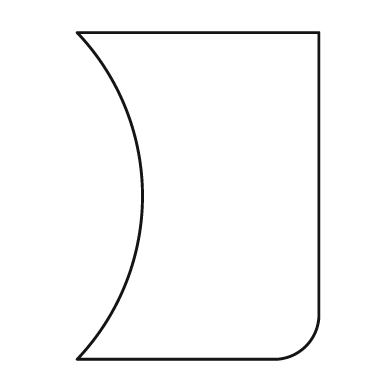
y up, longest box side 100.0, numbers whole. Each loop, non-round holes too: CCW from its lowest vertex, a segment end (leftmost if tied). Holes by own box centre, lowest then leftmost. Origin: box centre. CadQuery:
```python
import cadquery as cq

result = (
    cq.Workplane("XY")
    .moveTo(-37.0, -50.0)
    .lineTo(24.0, -50.0)
    .threePointArc((33.0, -46.0), (37.0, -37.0))
    .lineTo(37.0, 50.0)
    .lineTo(-37.0, 50.0)
    .threePointArc((-17.0, 0.0), (-37.0, -50.0))
    .close()
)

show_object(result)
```